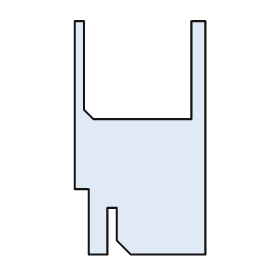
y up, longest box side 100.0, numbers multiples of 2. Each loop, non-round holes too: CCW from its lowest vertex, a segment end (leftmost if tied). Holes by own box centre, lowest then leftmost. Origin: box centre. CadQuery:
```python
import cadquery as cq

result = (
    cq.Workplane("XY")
    .moveTo(-22.0, -50.0)
    .lineTo(-14.0, -50.0)
    .lineTo(-14.0, -30.0)
    .lineTo(-10.0, -30.0)
    .lineTo(-10.0, -44.0)
    .lineTo(-4.0, -50.0)
    .lineTo(28.0, -50.0)
    .lineTo(28.0, 50.0)
    .lineTo(22.0, 50.0)
    .lineTo(22.0, 8.0)
    .lineTo(-20.0, 8.0)
    .lineTo(-24.0, 12.0)
    .lineTo(-24.0, 50.0)
    .lineTo(-28.0, 50.0)
    .lineTo(-28.0, -22.0)
    .lineTo(-22.0, -22.0)
    .close()
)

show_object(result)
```